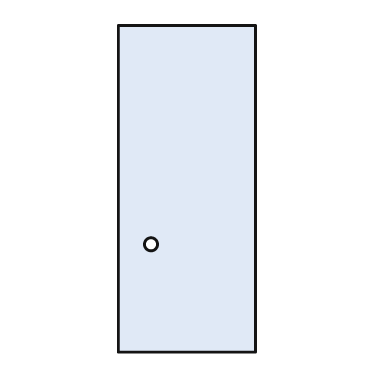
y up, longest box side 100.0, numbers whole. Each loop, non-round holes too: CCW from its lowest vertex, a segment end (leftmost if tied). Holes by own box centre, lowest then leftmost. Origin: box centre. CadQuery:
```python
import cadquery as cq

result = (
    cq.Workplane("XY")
    .moveTo(-21.0, -50.0)
    .lineTo(21.0, -50.0)
    .lineTo(21.0, 50.0)
    .lineTo(-21.0, 50.0)
    .close()
    .moveTo(-11.0, -17.0)
    .circle(2.0)
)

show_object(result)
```